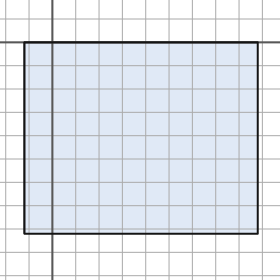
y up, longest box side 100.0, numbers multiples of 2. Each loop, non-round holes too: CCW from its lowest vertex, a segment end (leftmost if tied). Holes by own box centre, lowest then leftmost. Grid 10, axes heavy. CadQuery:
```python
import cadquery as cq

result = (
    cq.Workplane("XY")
    .moveTo(-12.0, -82.0)
    .lineTo(88.0, -82.0)
    .lineTo(88.0, 0.0)
    .lineTo(-12.0, 0.0)
    .close()
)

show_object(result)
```